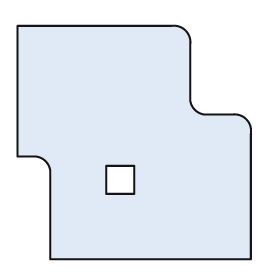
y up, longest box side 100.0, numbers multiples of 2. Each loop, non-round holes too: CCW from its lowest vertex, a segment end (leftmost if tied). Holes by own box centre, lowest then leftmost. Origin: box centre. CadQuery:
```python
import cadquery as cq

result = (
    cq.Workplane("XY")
    .moveTo(-36.0, -50.0)
    .lineTo(50.0, -50.0)
    .lineTo(50.0, 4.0)
    .threePointArc((48.0, 10.0), (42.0, 12.0))
    .lineTo(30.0, 12.0)
    .threePointArc((26.0, 14.0), (24.0, 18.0))
    .lineTo(24.0, 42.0)
    .threePointArc((22.0, 48.0), (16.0, 50.0))
    .lineTo(-50.0, 50.0)
    .lineTo(-50.0, -6.0)
    .lineTo(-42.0, -6.0)
    .threePointArc((-38.0, -8.0), (-36.0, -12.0))
    .close()
    .moveTo(-12.0, -22.0)
    .lineTo(0.0, -22.0)
    .lineTo(0.0, -10.0)
    .lineTo(-12.0, -10.0)
    .close()
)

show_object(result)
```